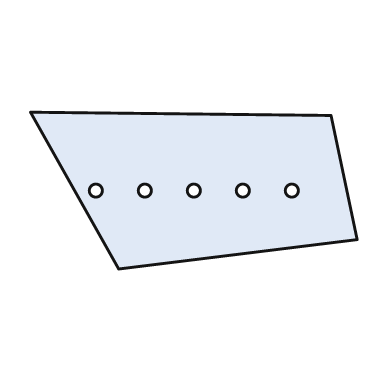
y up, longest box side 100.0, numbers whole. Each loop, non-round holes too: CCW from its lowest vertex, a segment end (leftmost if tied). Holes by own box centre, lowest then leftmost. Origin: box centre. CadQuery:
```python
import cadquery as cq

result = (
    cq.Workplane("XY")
    .moveTo(-23.0, -24.0)
    .lineTo(50.0, -15.0)
    .lineTo(42.0, 23.0)
    .lineTo(-50.0, 24.0)
    .close()
    .moveTo(-30.0, 0.0)
    .circle(2.0)
    .moveTo(-15.0, 0.0)
    .circle(2.0)
    .moveTo(0.0, 0.0)
    .circle(2.0)
    .moveTo(15.0, 0.0)
    .circle(2.0)
    .moveTo(30.0, 0.0)
    .circle(2.0)
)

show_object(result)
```